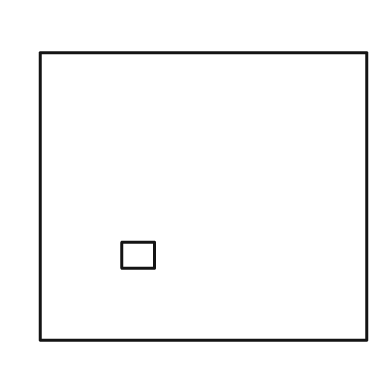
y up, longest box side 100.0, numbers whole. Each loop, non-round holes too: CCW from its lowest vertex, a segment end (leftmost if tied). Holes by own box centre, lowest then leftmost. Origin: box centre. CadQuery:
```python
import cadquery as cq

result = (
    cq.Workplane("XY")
    .moveTo(-50.0, -44.0)
    .lineTo(50.0, -44.0)
    .lineTo(50.0, 44.0)
    .lineTo(-50.0, 44.0)
    .close()
    .moveTo(-25.0, -22.0)
    .lineTo(-15.0, -22.0)
    .lineTo(-15.0, -14.0)
    .lineTo(-25.0, -14.0)
    .close()
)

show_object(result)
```